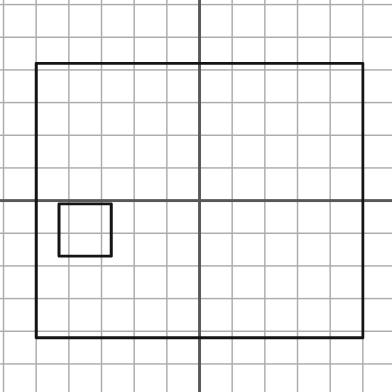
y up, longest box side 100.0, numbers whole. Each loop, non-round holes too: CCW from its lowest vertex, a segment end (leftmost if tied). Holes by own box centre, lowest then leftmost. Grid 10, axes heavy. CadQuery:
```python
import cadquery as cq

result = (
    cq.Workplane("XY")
    .moveTo(-50.0, -42.0)
    .lineTo(50.0, -42.0)
    .lineTo(50.0, 42.0)
    .lineTo(-50.0, 42.0)
    .close()
    .moveTo(-43.0, -17.0)
    .lineTo(-27.0, -17.0)
    .lineTo(-27.0, -1.0)
    .lineTo(-43.0, -1.0)
    .close()
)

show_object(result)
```